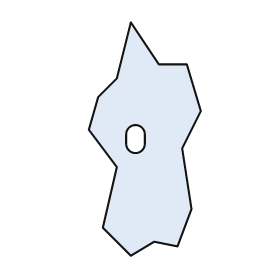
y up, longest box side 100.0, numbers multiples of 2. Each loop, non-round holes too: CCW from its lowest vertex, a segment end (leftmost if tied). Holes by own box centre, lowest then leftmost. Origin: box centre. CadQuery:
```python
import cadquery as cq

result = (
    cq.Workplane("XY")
    .moveTo(-6.0, -50.0)
    .lineTo(4.0, -44.0)
    .lineTo(14.0, -46.0)
    .lineTo(20.0, -30.0)
    .lineTo(16.0, -4.0)
    .lineTo(24.0, 12.0)
    .lineTo(18.0, 32.0)
    .lineTo(6.0, 32.0)
    .lineTo(-6.0, 50.0)
    .lineTo(-12.0, 26.0)
    .lineTo(-20.0, 18.0)
    .lineTo(-24.0, 4.0)
    .lineTo(-12.0, -12.0)
    .lineTo(-18.0, -38.0)
    .close()
    .moveTo(-8.0, -2.0)
    .threePointArc((-4.0, -6.0), (0.0, -2.0))
    .lineTo(0.0, 2.0)
    .threePointArc((-4.0, 6.0), (-8.0, 2.0))
    .close()
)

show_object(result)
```